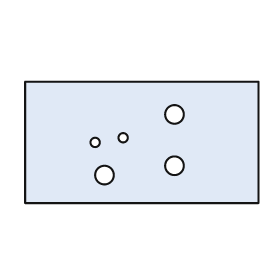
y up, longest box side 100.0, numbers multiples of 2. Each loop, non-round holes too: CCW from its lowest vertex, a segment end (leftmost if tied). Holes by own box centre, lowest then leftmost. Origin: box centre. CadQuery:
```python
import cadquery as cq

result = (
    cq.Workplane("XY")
    .moveTo(-50.0, -26.0)
    .lineTo(50.0, -26.0)
    .lineTo(50.0, 26.0)
    .lineTo(-50.0, 26.0)
    .close()
    .moveTo(-16.0, -14.0)
    .circle(4.0)
    .moveTo(14.0, -10.0)
    .circle(4.0)
    .moveTo(-20.0, 0.0)
    .circle(2.0)
    .moveTo(-8.0, 2.0)
    .circle(2.0)
    .moveTo(14.0, 12.0)
    .circle(4.0)
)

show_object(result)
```